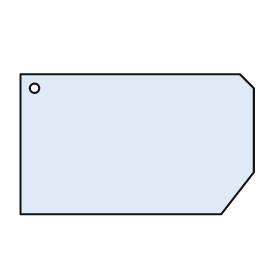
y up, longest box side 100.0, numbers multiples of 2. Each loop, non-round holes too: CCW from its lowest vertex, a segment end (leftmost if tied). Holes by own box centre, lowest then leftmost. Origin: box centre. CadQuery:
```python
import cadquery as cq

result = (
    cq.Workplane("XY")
    .moveTo(-50.0, -30.0)
    .lineTo(36.0, -30.0)
    .lineTo(50.0, -12.0)
    .lineTo(50.0, 24.0)
    .lineTo(44.0, 30.0)
    .lineTo(-50.0, 30.0)
    .close()
    .moveTo(-44.0, 24.0)
    .circle(2.0)
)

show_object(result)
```